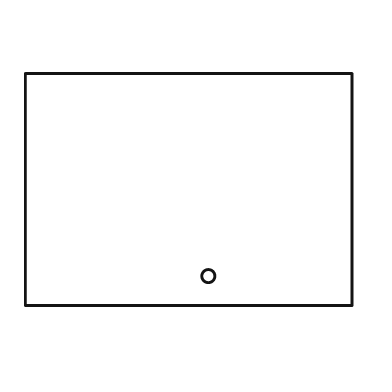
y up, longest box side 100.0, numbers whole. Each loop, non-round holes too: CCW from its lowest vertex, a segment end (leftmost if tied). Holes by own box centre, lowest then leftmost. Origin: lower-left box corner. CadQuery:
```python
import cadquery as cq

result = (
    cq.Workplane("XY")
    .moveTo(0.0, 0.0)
    .lineTo(100.0, 0.0)
    .lineTo(100.0, 71.0)
    .lineTo(0.0, 71.0)
    .close()
    .moveTo(56.0, 9.0)
    .circle(2.0)
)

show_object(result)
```